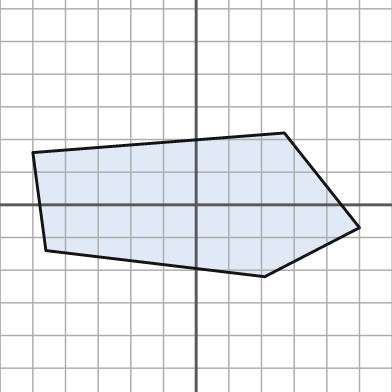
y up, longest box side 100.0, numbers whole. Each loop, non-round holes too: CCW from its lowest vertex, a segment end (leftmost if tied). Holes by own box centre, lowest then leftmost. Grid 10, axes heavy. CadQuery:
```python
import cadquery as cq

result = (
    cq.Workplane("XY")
    .moveTo(21.0, -22.0)
    .lineTo(50.0, -7.0)
    .lineTo(27.0, 22.0)
    .lineTo(-50.0, 16.0)
    .lineTo(-46.0, -14.0)
    .close()
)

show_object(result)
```